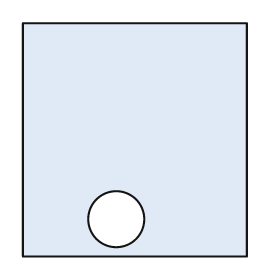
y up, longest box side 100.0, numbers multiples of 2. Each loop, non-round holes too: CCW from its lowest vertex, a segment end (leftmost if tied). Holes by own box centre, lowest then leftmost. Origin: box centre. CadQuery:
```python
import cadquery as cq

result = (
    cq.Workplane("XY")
    .moveTo(-48.0, -50.0)
    .lineTo(48.0, -50.0)
    .lineTo(48.0, 50.0)
    .lineTo(-48.0, 50.0)
    .close()
    .moveTo(-8.0, -34.0)
    .circle(12.0)
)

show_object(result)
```